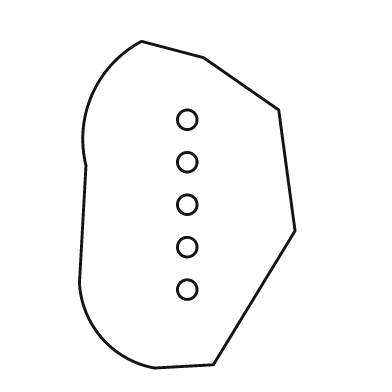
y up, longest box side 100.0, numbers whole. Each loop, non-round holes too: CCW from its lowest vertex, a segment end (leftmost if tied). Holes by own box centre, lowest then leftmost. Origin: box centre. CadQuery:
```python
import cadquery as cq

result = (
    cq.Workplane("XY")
    .moveTo(-10.0, -50.0)
    .lineTo(8.0, -49.0)
    .lineTo(33.0, -8.0)
    .lineTo(28.0, 29.0)
    .lineTo(5.0, 45.0)
    .lineTo(-14.0, 50.0)
    .threePointArc((-29.0, 34.0), (-31.0, 12.0))
    .lineTo(-33.0, -24.0)
    .threePointArc((-26.0, -41.0), (-10.0, -50.0))
    .close()
    .moveTo(0.0, -26.0)
    .circle(3.0)
    .moveTo(0.0, -13.0)
    .circle(3.0)
    .moveTo(0.0, 0.0)
    .circle(3.0)
    .moveTo(0.0, 13.0)
    .circle(3.0)
    .moveTo(0.0, 26.0)
    .circle(3.0)
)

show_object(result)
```